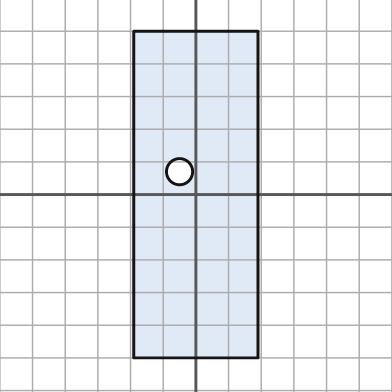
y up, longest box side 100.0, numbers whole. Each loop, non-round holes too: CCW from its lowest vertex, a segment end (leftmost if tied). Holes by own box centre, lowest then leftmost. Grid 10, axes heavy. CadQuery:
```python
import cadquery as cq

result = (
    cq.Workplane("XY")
    .moveTo(-19.0, -50.0)
    .lineTo(19.0, -50.0)
    .lineTo(19.0, 50.0)
    .lineTo(-19.0, 50.0)
    .close()
    .moveTo(-5.0, 7.0)
    .circle(4.0)
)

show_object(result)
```